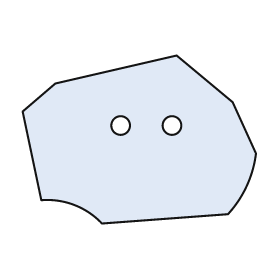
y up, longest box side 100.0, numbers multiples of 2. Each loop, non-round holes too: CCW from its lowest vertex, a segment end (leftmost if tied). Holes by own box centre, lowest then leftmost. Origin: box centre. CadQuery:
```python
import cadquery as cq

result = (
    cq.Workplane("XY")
    .moveTo(-16.0, -36.0)
    .lineTo(38.0, -32.0)
    .threePointArc((46.0, -20.0), (50.0, -6.0))
    .lineTo(40.0, 16.0)
    .lineTo(16.0, 36.0)
    .lineTo(-36.0, 24.0)
    .lineTo(-50.0, 12.0)
    .lineTo(-42.0, -26.0)
    .threePointArc((-28.0, -28.0), (-16.0, -36.0))
    .close()
    .moveTo(-8.0, 6.0)
    .circle(4.0)
    .moveTo(14.0, 6.0)
    .circle(4.0)
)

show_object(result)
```